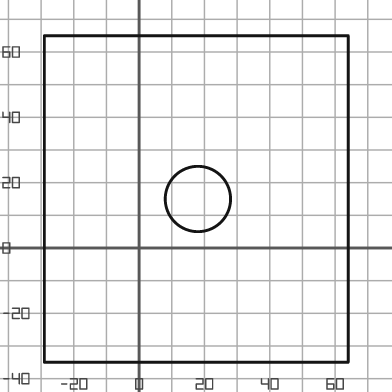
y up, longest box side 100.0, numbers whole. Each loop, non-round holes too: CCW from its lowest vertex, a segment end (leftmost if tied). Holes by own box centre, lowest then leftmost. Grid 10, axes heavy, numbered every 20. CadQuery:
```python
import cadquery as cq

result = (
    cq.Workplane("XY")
    .moveTo(-29.0, -35.0)
    .lineTo(64.0, -35.0)
    .lineTo(64.0, 65.0)
    .lineTo(-29.0, 65.0)
    .close()
    .moveTo(18.0, 15.0)
    .circle(10.0)
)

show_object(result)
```